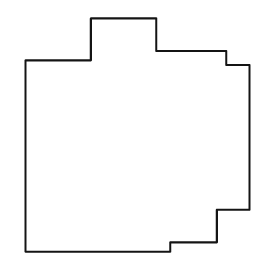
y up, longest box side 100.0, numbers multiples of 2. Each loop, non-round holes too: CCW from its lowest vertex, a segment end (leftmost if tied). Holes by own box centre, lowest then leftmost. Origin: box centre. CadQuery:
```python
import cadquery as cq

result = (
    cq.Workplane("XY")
    .moveTo(-48.0, -50.0)
    .lineTo(14.0, -50.0)
    .lineTo(14.0, -46.0)
    .lineTo(34.0, -46.0)
    .lineTo(34.0, -32.0)
    .lineTo(48.0, -32.0)
    .lineTo(48.0, 30.0)
    .lineTo(38.0, 30.0)
    .lineTo(38.0, 36.0)
    .lineTo(8.0, 36.0)
    .lineTo(8.0, 50.0)
    .lineTo(-20.0, 50.0)
    .lineTo(-20.0, 32.0)
    .lineTo(-48.0, 32.0)
    .close()
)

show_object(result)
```